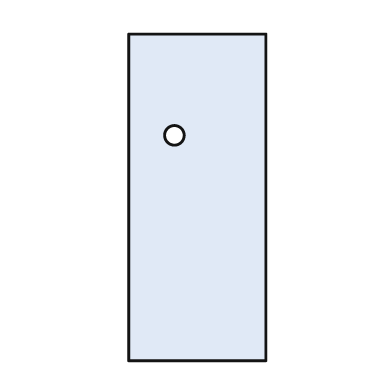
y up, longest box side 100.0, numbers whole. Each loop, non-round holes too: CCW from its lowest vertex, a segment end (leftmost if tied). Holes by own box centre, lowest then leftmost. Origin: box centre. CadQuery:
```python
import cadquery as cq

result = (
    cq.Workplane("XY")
    .moveTo(-21.0, -50.0)
    .lineTo(21.0, -50.0)
    .lineTo(21.0, 50.0)
    .lineTo(-21.0, 50.0)
    .close()
    .moveTo(-7.0, 19.0)
    .circle(3.0)
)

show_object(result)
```